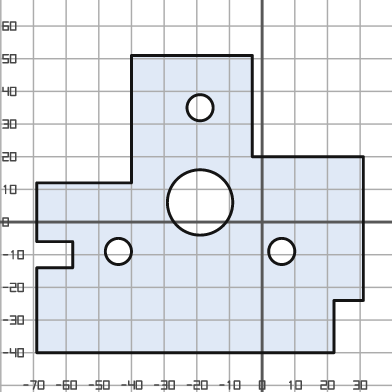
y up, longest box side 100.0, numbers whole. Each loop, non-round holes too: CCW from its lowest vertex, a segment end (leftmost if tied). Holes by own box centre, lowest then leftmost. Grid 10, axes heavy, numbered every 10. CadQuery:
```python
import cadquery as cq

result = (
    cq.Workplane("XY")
    .moveTo(-69.0, -40.0)
    .lineTo(22.0, -40.0)
    .lineTo(22.0, -24.0)
    .lineTo(31.0, -24.0)
    .lineTo(31.0, 20.0)
    .lineTo(-3.0, 20.0)
    .lineTo(-3.0, 51.0)
    .lineTo(-40.0, 51.0)
    .lineTo(-40.0, 12.0)
    .lineTo(-69.0, 12.0)
    .lineTo(-69.0, -6.0)
    .lineTo(-58.0, -6.0)
    .lineTo(-58.0, -14.0)
    .lineTo(-69.0, -14.0)
    .close()
    .moveTo(-44.0, -9.0)
    .circle(4.0)
    .moveTo(6.0, -9.0)
    .circle(4.0)
    .moveTo(-19.0, 6.0)
    .circle(10.0)
    .moveTo(-19.0, 35.0)
    .circle(4.0)
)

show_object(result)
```